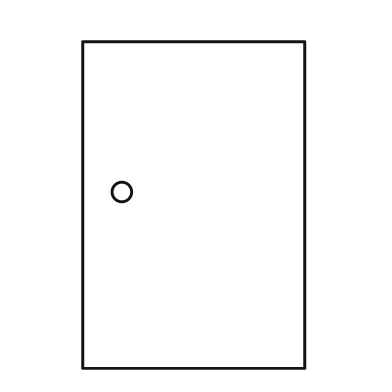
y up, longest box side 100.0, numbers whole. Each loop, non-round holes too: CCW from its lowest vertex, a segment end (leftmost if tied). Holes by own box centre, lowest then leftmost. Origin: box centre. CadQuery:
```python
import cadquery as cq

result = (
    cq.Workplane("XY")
    .moveTo(-34.0, -50.0)
    .lineTo(34.0, -50.0)
    .lineTo(34.0, 50.0)
    .lineTo(-34.0, 50.0)
    .close()
    .moveTo(-22.0, 4.0)
    .circle(3.0)
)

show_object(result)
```